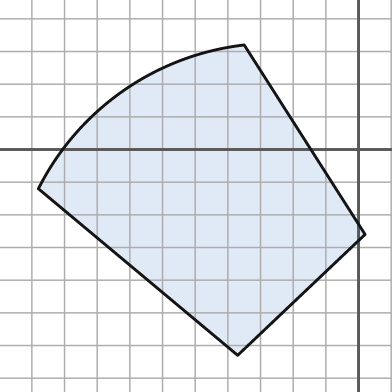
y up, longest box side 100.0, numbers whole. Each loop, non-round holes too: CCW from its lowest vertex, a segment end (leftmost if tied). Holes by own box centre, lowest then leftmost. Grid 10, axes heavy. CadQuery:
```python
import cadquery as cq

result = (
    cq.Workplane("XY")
    .moveTo(-37.0, -63.0)
    .lineTo(2.0, -26.0)
    .lineTo(-35.0, 32.0)
    .threePointArc((-72.0, 18.0), (-98.0, -12.0))
    .close()
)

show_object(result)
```